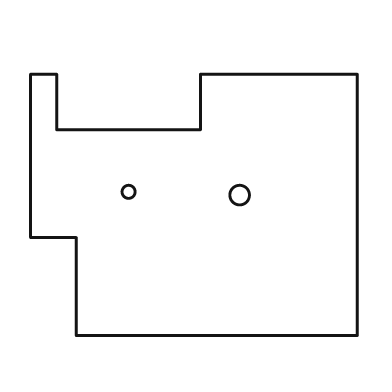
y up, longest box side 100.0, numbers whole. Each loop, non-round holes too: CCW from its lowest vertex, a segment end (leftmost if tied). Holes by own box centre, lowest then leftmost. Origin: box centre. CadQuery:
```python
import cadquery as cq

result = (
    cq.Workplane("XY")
    .moveTo(-36.0, -40.0)
    .lineTo(50.0, -40.0)
    .lineTo(50.0, 40.0)
    .lineTo(2.0, 40.0)
    .lineTo(2.0, 23.0)
    .lineTo(-42.0, 23.0)
    .lineTo(-42.0, 40.0)
    .lineTo(-50.0, 40.0)
    .lineTo(-50.0, -10.0)
    .lineTo(-36.0, -10.0)
    .close()
    .moveTo(14.0, 3.0)
    .circle(3.0)
    .moveTo(-20.0, 4.0)
    .circle(2.0)
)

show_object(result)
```